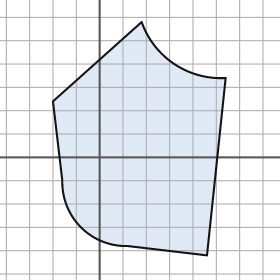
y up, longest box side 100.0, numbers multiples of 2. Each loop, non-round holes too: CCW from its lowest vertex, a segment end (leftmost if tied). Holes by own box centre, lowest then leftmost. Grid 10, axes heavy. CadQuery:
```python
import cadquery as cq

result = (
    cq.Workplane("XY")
    .moveTo(46.0, -42.0)
    .lineTo(54.0, 34.0)
    .threePointArc((32.0, 40.0), (18.0, 58.0))
    .lineTo(-20.0, 24.0)
    .lineTo(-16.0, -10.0)
    .threePointArc((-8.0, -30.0), (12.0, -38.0))
    .close()
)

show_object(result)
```